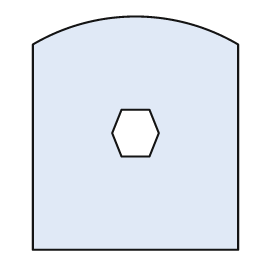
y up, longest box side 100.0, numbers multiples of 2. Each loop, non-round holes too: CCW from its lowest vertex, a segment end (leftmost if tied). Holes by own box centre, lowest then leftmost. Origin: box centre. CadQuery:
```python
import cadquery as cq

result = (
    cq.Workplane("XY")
    .moveTo(-44.0, -50.0)
    .lineTo(44.0, -50.0)
    .lineTo(44.0, 38.0)
    .threePointArc((0.0, 50.0), (-44.0, 38.0))
    .close()
    .moveTo(-6.0, -10.0)
    .lineTo(6.0, -10.0)
    .lineTo(10.0, 0.0)
    .lineTo(6.0, 10.0)
    .lineTo(-6.0, 10.0)
    .lineTo(-10.0, 0.0)
    .close()
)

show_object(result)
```